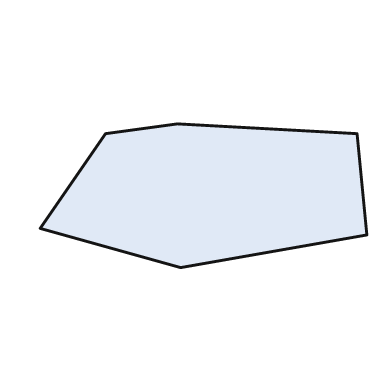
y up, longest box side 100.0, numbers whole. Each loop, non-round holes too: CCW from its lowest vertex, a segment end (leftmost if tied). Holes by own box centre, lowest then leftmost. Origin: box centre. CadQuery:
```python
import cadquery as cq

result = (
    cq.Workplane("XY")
    .moveTo(-7.0, -22.0)
    .lineTo(50.0, -12.0)
    .lineTo(47.0, 19.0)
    .lineTo(-8.0, 22.0)
    .lineTo(-30.0, 19.0)
    .lineTo(-50.0, -10.0)
    .close()
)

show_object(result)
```